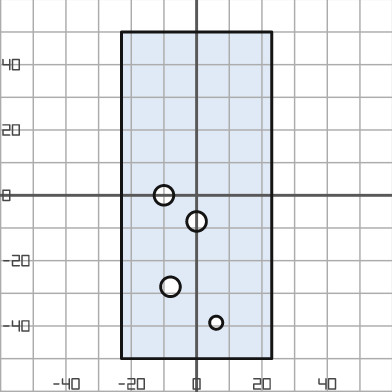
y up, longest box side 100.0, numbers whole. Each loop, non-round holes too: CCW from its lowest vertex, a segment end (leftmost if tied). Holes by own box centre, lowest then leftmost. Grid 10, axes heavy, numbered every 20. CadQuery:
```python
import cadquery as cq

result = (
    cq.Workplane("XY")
    .moveTo(-23.0, -50.0)
    .lineTo(23.0, -50.0)
    .lineTo(23.0, 50.0)
    .lineTo(-23.0, 50.0)
    .close()
    .moveTo(6.0, -39.0)
    .circle(2.0)
    .moveTo(-8.0, -28.0)
    .circle(3.0)
    .moveTo(0.0, -8.0)
    .circle(3.0)
    .moveTo(-10.0, 0.0)
    .circle(3.0)
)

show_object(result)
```